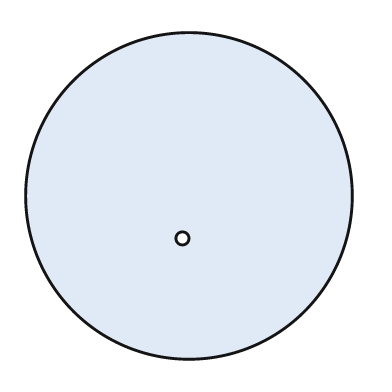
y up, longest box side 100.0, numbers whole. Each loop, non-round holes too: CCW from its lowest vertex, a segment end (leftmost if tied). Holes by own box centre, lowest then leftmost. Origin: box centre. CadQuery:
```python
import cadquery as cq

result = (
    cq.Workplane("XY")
    .moveTo(0.0, 0.0)
    .circle(50.0)
    .moveTo(-2.0, -13.0)
    .circle(2.0)
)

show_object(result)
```